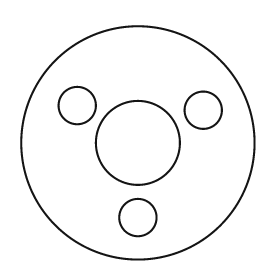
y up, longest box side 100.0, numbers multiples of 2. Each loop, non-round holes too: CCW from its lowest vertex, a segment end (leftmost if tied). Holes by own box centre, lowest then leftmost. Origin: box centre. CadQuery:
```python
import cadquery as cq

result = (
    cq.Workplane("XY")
    .moveTo(0.0, 0.0)
    .circle(50.0)
    .moveTo(0.0, -32.0)
    .circle(8.0)
    .moveTo(0.0, 0.0)
    .circle(18.0)
    .moveTo(28.0, 14.0)
    .circle(8.0)
    .moveTo(-26.0, 16.0)
    .circle(8.0)
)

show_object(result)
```